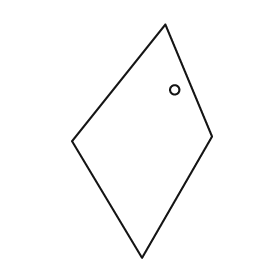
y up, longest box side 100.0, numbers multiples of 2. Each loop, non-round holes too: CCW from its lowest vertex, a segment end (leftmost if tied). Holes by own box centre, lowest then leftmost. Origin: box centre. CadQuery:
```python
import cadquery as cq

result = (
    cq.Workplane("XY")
    .moveTo(0.0, -50.0)
    .lineTo(30.0, 2.0)
    .lineTo(10.0, 50.0)
    .lineTo(-30.0, 0.0)
    .close()
    .moveTo(14.0, 22.0)
    .circle(2.0)
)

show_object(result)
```